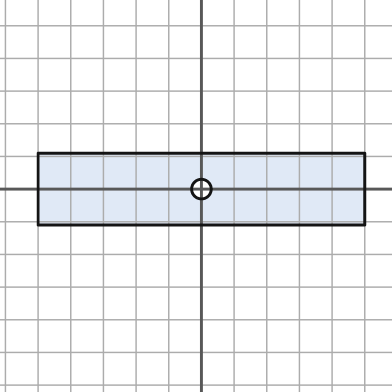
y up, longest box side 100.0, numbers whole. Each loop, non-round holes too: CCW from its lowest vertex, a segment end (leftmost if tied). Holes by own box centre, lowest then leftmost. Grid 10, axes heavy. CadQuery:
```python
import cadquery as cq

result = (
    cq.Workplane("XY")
    .moveTo(-50.0, -11.0)
    .lineTo(50.0, -11.0)
    .lineTo(50.0, 11.0)
    .lineTo(-50.0, 11.0)
    .close()
    .moveTo(0.0, 0.0)
    .circle(3.0)
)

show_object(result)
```